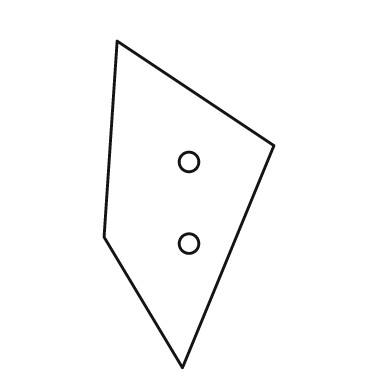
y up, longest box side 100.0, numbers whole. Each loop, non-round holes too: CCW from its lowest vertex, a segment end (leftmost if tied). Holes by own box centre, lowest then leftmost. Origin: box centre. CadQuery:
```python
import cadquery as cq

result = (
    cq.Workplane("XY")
    .moveTo(-2.0, -50.0)
    .lineTo(26.0, 18.0)
    .lineTo(-22.0, 50.0)
    .lineTo(-26.0, -10.0)
    .close()
    .moveTo(0.0, -12.0)
    .circle(3.0)
    .moveTo(0.0, 13.0)
    .circle(3.0)
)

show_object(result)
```